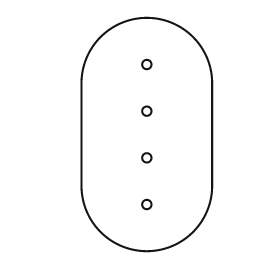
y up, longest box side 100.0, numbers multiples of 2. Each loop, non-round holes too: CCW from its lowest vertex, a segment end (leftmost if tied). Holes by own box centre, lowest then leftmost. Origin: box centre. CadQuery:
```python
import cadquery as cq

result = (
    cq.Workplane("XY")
    .moveTo(-28.0, -22.0)
    .threePointArc((0.0, -50.0), (28.0, -22.0))
    .lineTo(28.0, 22.0)
    .threePointArc((0.0, 50.0), (-28.0, 22.0))
    .close()
    .moveTo(0.0, -30.0)
    .circle(2.0)
    .moveTo(0.0, -10.0)
    .circle(2.0)
    .moveTo(0.0, 10.0)
    .circle(2.0)
    .moveTo(0.0, 30.0)
    .circle(2.0)
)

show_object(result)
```